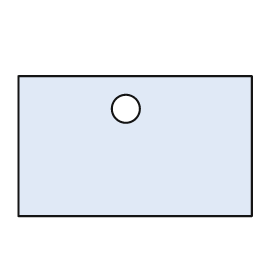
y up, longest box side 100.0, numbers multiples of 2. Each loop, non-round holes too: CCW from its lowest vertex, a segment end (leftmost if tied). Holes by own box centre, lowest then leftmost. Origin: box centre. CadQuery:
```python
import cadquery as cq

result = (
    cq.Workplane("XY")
    .moveTo(-50.0, -30.0)
    .lineTo(50.0, -30.0)
    .lineTo(50.0, 30.0)
    .lineTo(-50.0, 30.0)
    .close()
    .moveTo(-4.0, 16.0)
    .circle(6.0)
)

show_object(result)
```